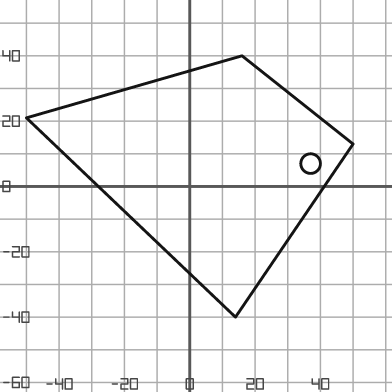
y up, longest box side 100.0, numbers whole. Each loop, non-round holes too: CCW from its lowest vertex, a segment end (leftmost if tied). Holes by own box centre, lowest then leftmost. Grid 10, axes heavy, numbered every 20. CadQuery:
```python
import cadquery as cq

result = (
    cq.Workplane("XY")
    .moveTo(14.0, -40.0)
    .lineTo(50.0, 13.0)
    .lineTo(16.0, 40.0)
    .lineTo(-50.0, 21.0)
    .close()
    .moveTo(37.0, 7.0)
    .circle(3.0)
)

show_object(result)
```